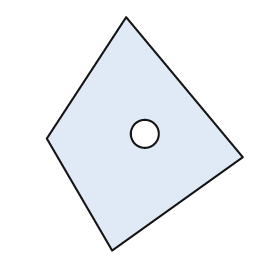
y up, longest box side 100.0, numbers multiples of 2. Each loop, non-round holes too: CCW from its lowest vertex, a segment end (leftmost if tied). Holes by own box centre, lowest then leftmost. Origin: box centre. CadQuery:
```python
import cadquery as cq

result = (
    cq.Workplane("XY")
    .moveTo(-14.0, -50.0)
    .lineTo(42.0, -10.0)
    .lineTo(-8.0, 50.0)
    .lineTo(-42.0, -2.0)
    .close()
    .moveTo(0.0, 0.0)
    .circle(6.0)
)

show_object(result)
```